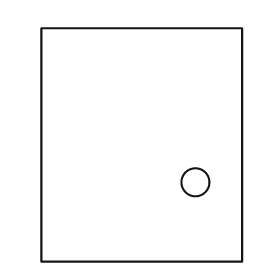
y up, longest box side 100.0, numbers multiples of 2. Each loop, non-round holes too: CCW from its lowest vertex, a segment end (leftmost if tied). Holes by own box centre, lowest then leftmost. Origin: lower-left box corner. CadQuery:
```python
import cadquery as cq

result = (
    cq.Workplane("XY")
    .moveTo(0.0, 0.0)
    .lineTo(86.0, 0.0)
    .lineTo(86.0, 100.0)
    .lineTo(0.0, 100.0)
    .close()
    .moveTo(66.0, 34.0)
    .circle(6.0)
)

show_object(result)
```